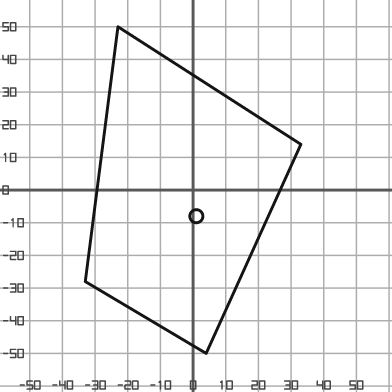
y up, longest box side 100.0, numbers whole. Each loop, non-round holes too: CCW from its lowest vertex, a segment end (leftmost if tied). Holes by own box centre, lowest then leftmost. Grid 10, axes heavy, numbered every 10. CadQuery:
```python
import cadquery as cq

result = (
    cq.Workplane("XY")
    .moveTo(4.0, -50.0)
    .lineTo(33.0, 14.0)
    .lineTo(-23.0, 50.0)
    .lineTo(-33.0, -28.0)
    .close()
    .moveTo(1.0, -8.0)
    .circle(2.0)
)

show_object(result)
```